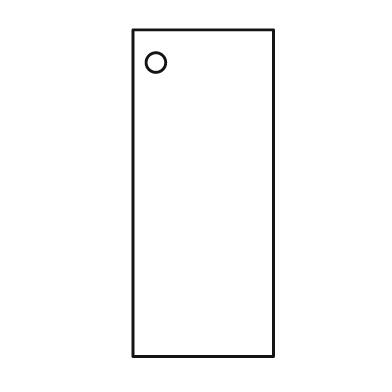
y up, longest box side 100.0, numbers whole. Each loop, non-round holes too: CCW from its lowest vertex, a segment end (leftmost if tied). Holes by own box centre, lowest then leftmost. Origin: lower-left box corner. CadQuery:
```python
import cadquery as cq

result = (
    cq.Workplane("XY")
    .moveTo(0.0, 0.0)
    .lineTo(43.0, 0.0)
    .lineTo(43.0, 100.0)
    .lineTo(0.0, 100.0)
    .close()
    .moveTo(7.0, 90.0)
    .circle(3.0)
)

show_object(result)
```